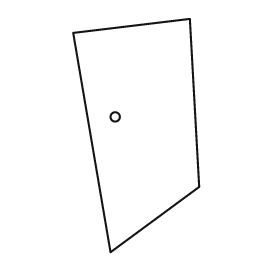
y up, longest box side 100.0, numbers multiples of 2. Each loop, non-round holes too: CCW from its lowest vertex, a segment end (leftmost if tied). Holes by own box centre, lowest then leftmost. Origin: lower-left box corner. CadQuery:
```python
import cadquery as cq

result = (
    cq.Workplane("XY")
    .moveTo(16.0, 0.0)
    .lineTo(54.0, 28.0)
    .lineTo(50.0, 100.0)
    .lineTo(0.0, 94.0)
    .close()
    .moveTo(18.0, 58.0)
    .circle(2.0)
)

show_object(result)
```